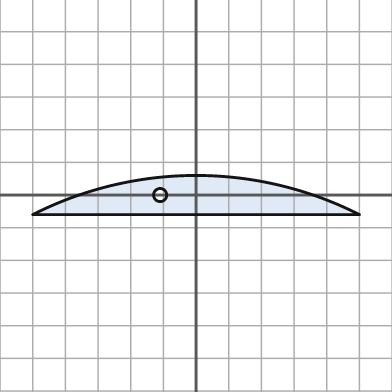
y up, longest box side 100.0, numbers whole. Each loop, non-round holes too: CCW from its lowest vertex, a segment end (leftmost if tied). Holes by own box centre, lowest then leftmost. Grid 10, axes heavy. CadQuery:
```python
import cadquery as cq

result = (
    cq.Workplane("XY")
    .moveTo(-50.0, -6.0)
    .lineTo(50.0, -6.0)
    .threePointArc((0.0, 6.0), (-50.0, -6.0))
    .close()
    .moveTo(-11.0, 0.0)
    .circle(2.0)
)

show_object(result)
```